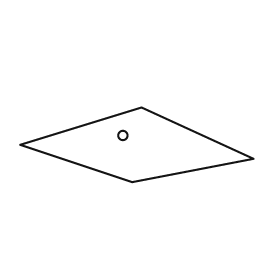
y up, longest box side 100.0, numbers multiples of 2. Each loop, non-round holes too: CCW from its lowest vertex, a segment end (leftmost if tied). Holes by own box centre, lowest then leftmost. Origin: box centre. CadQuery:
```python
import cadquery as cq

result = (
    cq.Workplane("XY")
    .moveTo(-2.0, -16.0)
    .lineTo(50.0, -6.0)
    .lineTo(2.0, 16.0)
    .lineTo(-50.0, 0.0)
    .close()
    .moveTo(-6.0, 4.0)
    .circle(2.0)
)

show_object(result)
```